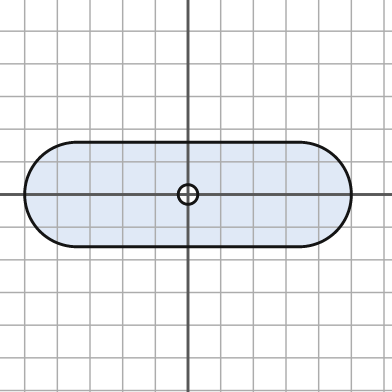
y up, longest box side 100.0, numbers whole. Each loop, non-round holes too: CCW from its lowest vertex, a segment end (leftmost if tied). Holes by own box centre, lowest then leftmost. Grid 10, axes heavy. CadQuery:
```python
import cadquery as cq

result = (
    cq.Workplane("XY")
    .moveTo(-34.0, -16.0)
    .lineTo(34.0, -16.0)
    .threePointArc((50.0, 0.0), (34.0, 16.0))
    .lineTo(-34.0, 16.0)
    .threePointArc((-50.0, 0.0), (-34.0, -16.0))
    .close()
    .moveTo(0.0, 0.0)
    .circle(3.0)
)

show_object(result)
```